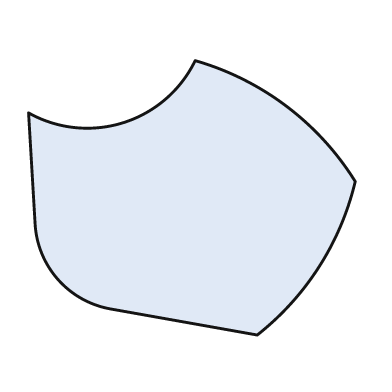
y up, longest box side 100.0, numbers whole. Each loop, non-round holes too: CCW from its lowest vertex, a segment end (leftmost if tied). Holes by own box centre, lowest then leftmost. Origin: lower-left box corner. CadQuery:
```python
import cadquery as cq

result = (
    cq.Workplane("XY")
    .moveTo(70.0, 0.0)
    .threePointArc((89.0, 21.0), (100.0, 47.0))
    .threePointArc((79.0, 70.0), (51.0, 84.0))
    .threePointArc((29.0, 65.0), (0.0, 68.0))
    .lineTo(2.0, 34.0)
    .threePointArc((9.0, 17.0), (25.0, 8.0))
    .close()
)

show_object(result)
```